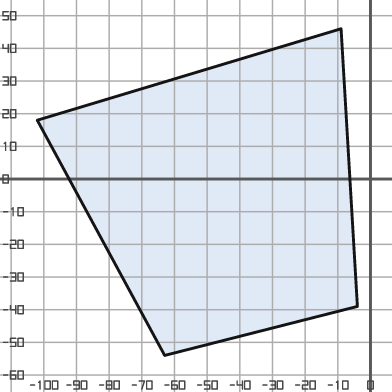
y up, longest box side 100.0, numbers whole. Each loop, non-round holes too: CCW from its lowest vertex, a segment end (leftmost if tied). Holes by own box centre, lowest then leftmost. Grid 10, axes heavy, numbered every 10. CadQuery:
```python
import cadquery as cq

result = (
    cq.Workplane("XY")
    .moveTo(-63.0, -54.0)
    .lineTo(-4.0, -39.0)
    .lineTo(-9.0, 46.0)
    .lineTo(-102.0, 18.0)
    .close()
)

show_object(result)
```